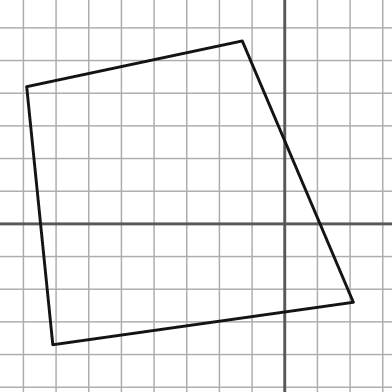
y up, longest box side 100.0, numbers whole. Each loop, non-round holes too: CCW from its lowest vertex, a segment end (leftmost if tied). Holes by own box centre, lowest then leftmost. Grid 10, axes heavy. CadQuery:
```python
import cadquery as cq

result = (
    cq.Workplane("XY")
    .moveTo(-71.0, -37.0)
    .lineTo(21.0, -24.0)
    .lineTo(-13.0, 56.0)
    .lineTo(-79.0, 42.0)
    .close()
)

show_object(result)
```